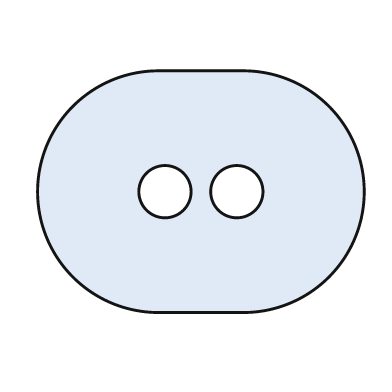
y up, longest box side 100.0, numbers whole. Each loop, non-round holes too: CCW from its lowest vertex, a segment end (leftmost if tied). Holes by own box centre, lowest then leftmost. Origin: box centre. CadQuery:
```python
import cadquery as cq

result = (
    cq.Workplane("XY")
    .moveTo(-13.0, -37.0)
    .lineTo(13.0, -37.0)
    .threePointArc((50.0, 0.0), (13.0, 37.0))
    .lineTo(-13.0, 37.0)
    .threePointArc((-50.0, 0.0), (-13.0, -37.0))
    .close()
    .moveTo(-11.0, 0.0)
    .circle(8.0)
    .moveTo(11.0, 0.0)
    .circle(8.0)
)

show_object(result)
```